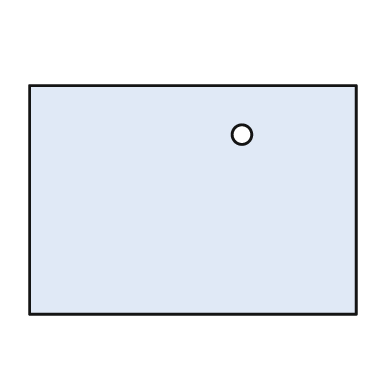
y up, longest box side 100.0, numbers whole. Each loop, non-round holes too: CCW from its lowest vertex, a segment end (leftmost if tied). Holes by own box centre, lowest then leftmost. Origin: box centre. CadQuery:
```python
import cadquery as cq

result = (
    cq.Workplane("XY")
    .moveTo(-50.0, -35.0)
    .lineTo(50.0, -35.0)
    .lineTo(50.0, 35.0)
    .lineTo(-50.0, 35.0)
    .close()
    .moveTo(15.0, 20.0)
    .circle(3.0)
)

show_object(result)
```